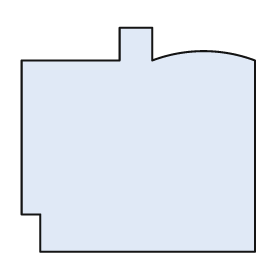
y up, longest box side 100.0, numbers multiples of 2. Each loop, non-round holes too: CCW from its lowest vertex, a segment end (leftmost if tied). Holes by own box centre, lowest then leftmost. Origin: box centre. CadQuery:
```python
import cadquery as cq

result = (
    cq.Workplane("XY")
    .moveTo(-42.0, -48.0)
    .lineTo(50.0, -48.0)
    .lineTo(50.0, 34.0)
    .threePointArc((28.0, 38.0), (6.0, 34.0))
    .lineTo(6.0, 48.0)
    .lineTo(-8.0, 48.0)
    .lineTo(-8.0, 34.0)
    .lineTo(-50.0, 34.0)
    .lineTo(-50.0, -32.0)
    .lineTo(-42.0, -32.0)
    .close()
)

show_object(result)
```